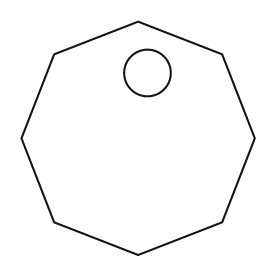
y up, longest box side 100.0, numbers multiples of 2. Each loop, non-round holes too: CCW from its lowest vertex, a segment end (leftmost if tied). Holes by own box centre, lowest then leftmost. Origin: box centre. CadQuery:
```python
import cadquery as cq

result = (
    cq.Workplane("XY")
    .moveTo(0.0, -50.0)
    .lineTo(36.0, -36.0)
    .lineTo(50.0, 0.0)
    .lineTo(36.0, 36.0)
    .lineTo(0.0, 50.0)
    .lineTo(-36.0, 36.0)
    .lineTo(-50.0, 0.0)
    .lineTo(-36.0, -36.0)
    .close()
    .moveTo(4.0, 28.0)
    .circle(10.0)
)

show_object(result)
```